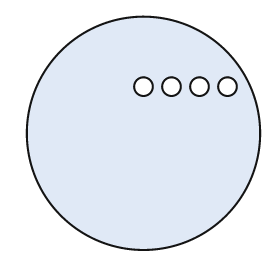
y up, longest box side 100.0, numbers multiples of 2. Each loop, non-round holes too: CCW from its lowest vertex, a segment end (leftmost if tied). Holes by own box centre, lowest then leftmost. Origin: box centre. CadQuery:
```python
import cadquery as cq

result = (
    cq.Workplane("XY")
    .moveTo(0.0, 0.0)
    .circle(50.0)
    .moveTo(0.0, 20.0)
    .circle(4.0)
    .moveTo(12.0, 20.0)
    .circle(4.0)
    .moveTo(24.0, 20.0)
    .circle(4.0)
    .moveTo(36.0, 20.0)
    .circle(4.0)
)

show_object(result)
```